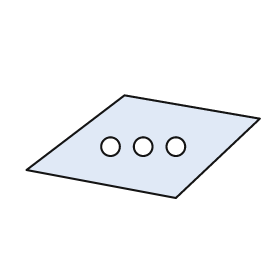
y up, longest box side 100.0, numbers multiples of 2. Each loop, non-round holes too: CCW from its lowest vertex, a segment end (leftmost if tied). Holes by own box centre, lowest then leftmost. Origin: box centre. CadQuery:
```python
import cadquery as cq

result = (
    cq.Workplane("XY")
    .moveTo(14.0, -22.0)
    .lineTo(50.0, 12.0)
    .lineTo(-8.0, 22.0)
    .lineTo(-50.0, -10.0)
    .close()
    .moveTo(-14.0, 0.0)
    .circle(4.0)
    .moveTo(0.0, 0.0)
    .circle(4.0)
    .moveTo(14.0, 0.0)
    .circle(4.0)
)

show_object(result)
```